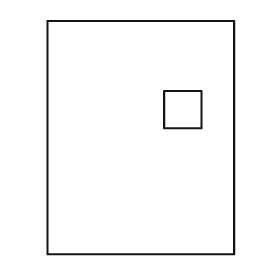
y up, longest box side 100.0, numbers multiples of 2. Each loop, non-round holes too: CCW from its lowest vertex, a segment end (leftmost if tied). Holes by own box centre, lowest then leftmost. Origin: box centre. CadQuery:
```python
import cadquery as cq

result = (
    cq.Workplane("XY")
    .moveTo(-40.0, -50.0)
    .lineTo(40.0, -50.0)
    .lineTo(40.0, 50.0)
    .lineTo(-40.0, 50.0)
    .close()
    .moveTo(10.0, 4.0)
    .lineTo(26.0, 4.0)
    .lineTo(26.0, 20.0)
    .lineTo(10.0, 20.0)
    .close()
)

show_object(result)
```